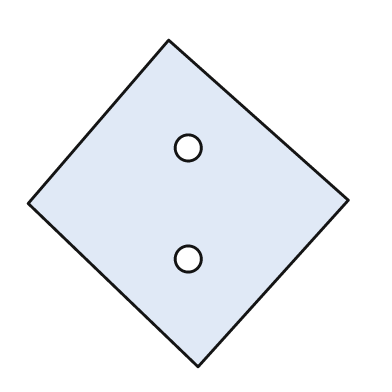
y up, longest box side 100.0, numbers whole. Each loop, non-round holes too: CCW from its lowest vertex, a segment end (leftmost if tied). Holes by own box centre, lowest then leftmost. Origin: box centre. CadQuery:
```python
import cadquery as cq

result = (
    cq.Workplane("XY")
    .moveTo(3.0, -50.0)
    .lineTo(49.0, 1.0)
    .lineTo(-6.0, 50.0)
    .lineTo(-49.0, 0.0)
    .close()
    .moveTo(0.0, -17.0)
    .circle(4.0)
    .moveTo(0.0, 17.0)
    .circle(4.0)
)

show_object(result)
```